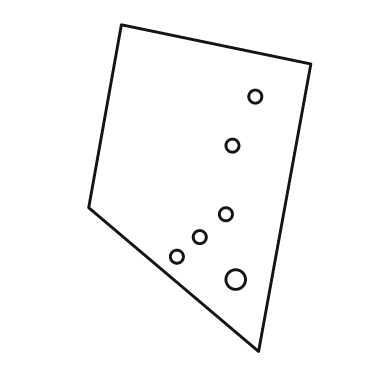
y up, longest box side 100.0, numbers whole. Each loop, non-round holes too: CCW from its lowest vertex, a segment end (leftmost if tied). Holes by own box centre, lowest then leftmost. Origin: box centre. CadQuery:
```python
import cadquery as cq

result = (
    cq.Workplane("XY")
    .moveTo(18.0, -50.0)
    .lineTo(34.0, 38.0)
    .lineTo(-24.0, 50.0)
    .lineTo(-34.0, -6.0)
    .close()
    .moveTo(11.0, -28.0)
    .circle(3.0)
    .moveTo(-7.0, -21.0)
    .circle(2.0)
    .moveTo(0.0, -15.0)
    .circle(2.0)
    .moveTo(8.0, -8.0)
    .circle(2.0)
    .moveTo(10.0, 13.0)
    .circle(2.0)
    .moveTo(17.0, 28.0)
    .circle(2.0)
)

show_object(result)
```